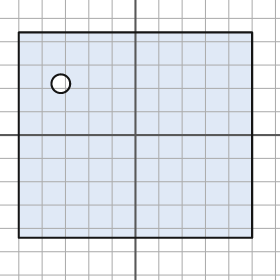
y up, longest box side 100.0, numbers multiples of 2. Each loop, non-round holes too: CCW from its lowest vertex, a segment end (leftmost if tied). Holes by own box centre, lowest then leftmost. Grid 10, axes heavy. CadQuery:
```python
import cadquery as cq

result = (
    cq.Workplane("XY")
    .moveTo(-50.0, -44.0)
    .lineTo(50.0, -44.0)
    .lineTo(50.0, 44.0)
    .lineTo(-50.0, 44.0)
    .close()
    .moveTo(-32.0, 22.0)
    .circle(4.0)
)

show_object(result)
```